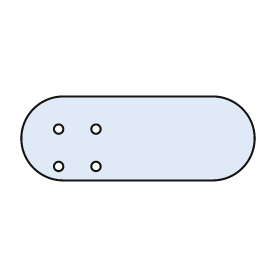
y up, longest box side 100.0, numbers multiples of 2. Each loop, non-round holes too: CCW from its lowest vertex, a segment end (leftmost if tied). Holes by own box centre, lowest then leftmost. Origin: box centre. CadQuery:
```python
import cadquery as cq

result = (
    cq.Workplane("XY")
    .moveTo(-32.0, -18.0)
    .lineTo(32.0, -18.0)
    .threePointArc((50.0, 0.0), (32.0, 18.0))
    .lineTo(-32.0, 18.0)
    .threePointArc((-50.0, 0.0), (-32.0, -18.0))
    .close()
    .moveTo(-34.0, -12.0)
    .circle(2.0)
    .moveTo(-18.0, -12.0)
    .circle(2.0)
    .moveTo(-34.0, 4.0)
    .circle(2.0)
    .moveTo(-18.0, 4.0)
    .circle(2.0)
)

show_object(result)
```